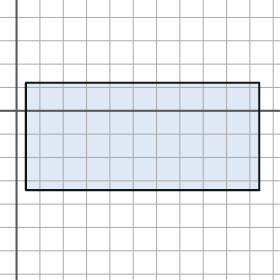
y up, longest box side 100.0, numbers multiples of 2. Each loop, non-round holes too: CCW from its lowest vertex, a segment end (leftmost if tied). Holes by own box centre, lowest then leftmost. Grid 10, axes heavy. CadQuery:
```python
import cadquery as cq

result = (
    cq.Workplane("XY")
    .moveTo(4.0, -34.0)
    .lineTo(104.0, -34.0)
    .lineTo(104.0, 12.0)
    .lineTo(4.0, 12.0)
    .close()
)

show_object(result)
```